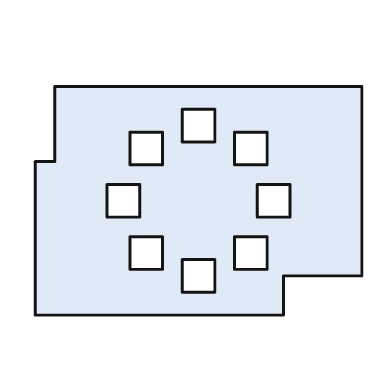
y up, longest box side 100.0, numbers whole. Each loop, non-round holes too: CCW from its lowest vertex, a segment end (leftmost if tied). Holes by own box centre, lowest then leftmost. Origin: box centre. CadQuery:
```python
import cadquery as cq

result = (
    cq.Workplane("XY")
    .moveTo(-50.0, -35.0)
    .lineTo(26.0, -35.0)
    .lineTo(26.0, -23.0)
    .lineTo(50.0, -23.0)
    .lineTo(50.0, 35.0)
    .lineTo(-44.0, 35.0)
    .lineTo(-44.0, 12.0)
    .lineTo(-50.0, 12.0)
    .close()
    .moveTo(-5.0, -28.0)
    .lineTo(5.0, -28.0)
    .lineTo(5.0, -18.0)
    .lineTo(-5.0, -18.0)
    .close()
    .moveTo(-21.0, -21.0)
    .lineTo(-11.0, -21.0)
    .lineTo(-11.0, -11.0)
    .lineTo(-21.0, -11.0)
    .close()
    .moveTo(11.0, -21.0)
    .lineTo(21.0, -21.0)
    .lineTo(21.0, -11.0)
    .lineTo(11.0, -11.0)
    .close()
    .moveTo(-28.0, -5.0)
    .lineTo(-18.0, -5.0)
    .lineTo(-18.0, 5.0)
    .lineTo(-28.0, 5.0)
    .close()
    .moveTo(18.0, -5.0)
    .lineTo(28.0, -5.0)
    .lineTo(28.0, 5.0)
    .lineTo(18.0, 5.0)
    .close()
    .moveTo(-21.0, 11.0)
    .lineTo(-11.0, 11.0)
    .lineTo(-11.0, 21.0)
    .lineTo(-21.0, 21.0)
    .close()
    .moveTo(11.0, 11.0)
    .lineTo(21.0, 11.0)
    .lineTo(21.0, 21.0)
    .lineTo(11.0, 21.0)
    .close()
    .moveTo(-5.0, 18.0)
    .lineTo(5.0, 18.0)
    .lineTo(5.0, 28.0)
    .lineTo(-5.0, 28.0)
    .close()
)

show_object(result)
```